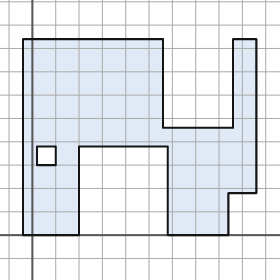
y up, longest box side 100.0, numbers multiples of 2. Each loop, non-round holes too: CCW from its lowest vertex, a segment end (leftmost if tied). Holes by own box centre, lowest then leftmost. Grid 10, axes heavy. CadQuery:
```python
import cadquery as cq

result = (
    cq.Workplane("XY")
    .moveTo(-4.0, 0.0)
    .lineTo(20.0, 0.0)
    .lineTo(20.0, 38.0)
    .lineTo(58.0, 38.0)
    .lineTo(58.0, 0.0)
    .lineTo(84.0, 0.0)
    .lineTo(84.0, 18.0)
    .lineTo(96.0, 18.0)
    .lineTo(96.0, 84.0)
    .lineTo(86.0, 84.0)
    .lineTo(86.0, 46.0)
    .lineTo(56.0, 46.0)
    .lineTo(56.0, 84.0)
    .lineTo(-4.0, 84.0)
    .close()
    .moveTo(2.0, 30.0)
    .lineTo(10.0, 30.0)
    .lineTo(10.0, 38.0)
    .lineTo(2.0, 38.0)
    .close()
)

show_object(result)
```